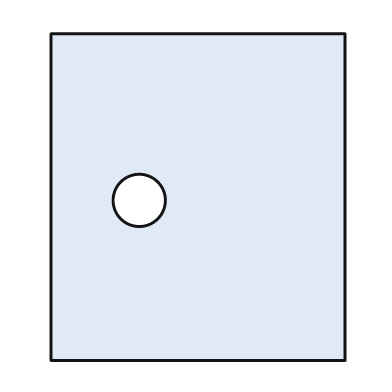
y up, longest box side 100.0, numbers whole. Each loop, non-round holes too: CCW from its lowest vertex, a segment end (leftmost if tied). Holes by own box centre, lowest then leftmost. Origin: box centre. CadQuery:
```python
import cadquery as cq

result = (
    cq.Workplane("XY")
    .moveTo(-45.0, -50.0)
    .lineTo(45.0, -50.0)
    .lineTo(45.0, 50.0)
    .lineTo(-45.0, 50.0)
    .close()
    .moveTo(-18.0, -1.0)
    .circle(8.0)
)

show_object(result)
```